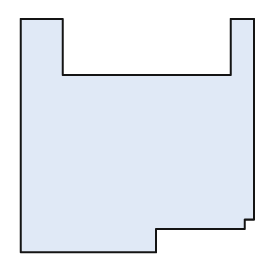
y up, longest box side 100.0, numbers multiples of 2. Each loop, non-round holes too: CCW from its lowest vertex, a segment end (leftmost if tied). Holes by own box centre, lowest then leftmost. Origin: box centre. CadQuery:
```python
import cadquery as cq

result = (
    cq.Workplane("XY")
    .moveTo(-50.0, -50.0)
    .lineTo(8.0, -50.0)
    .lineTo(8.0, -40.0)
    .lineTo(46.0, -40.0)
    .lineTo(46.0, -36.0)
    .lineTo(50.0, -36.0)
    .lineTo(50.0, 50.0)
    .lineTo(40.0, 50.0)
    .lineTo(40.0, 26.0)
    .lineTo(-32.0, 26.0)
    .lineTo(-32.0, 50.0)
    .lineTo(-50.0, 50.0)
    .close()
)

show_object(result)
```